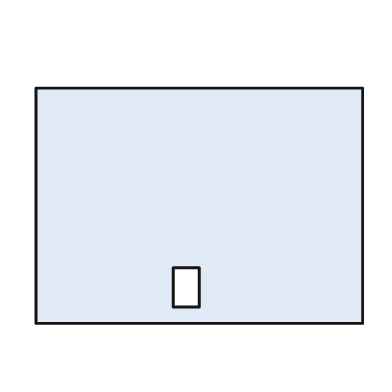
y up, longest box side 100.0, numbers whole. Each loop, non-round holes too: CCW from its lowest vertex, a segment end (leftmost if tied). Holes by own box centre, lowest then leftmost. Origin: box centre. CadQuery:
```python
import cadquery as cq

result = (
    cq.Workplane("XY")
    .moveTo(-50.0, -36.0)
    .lineTo(50.0, -36.0)
    .lineTo(50.0, 36.0)
    .lineTo(-50.0, 36.0)
    .close()
    .moveTo(-8.0, -31.0)
    .lineTo(0.0, -31.0)
    .lineTo(0.0, -19.0)
    .lineTo(-8.0, -19.0)
    .close()
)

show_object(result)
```